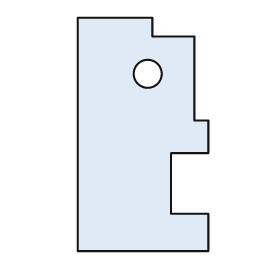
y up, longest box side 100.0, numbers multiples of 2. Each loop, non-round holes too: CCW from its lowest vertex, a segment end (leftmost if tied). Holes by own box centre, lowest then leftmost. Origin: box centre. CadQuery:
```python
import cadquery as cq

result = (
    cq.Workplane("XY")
    .moveTo(-28.0, -50.0)
    .lineTo(28.0, -50.0)
    .lineTo(28.0, -34.0)
    .lineTo(12.0, -34.0)
    .lineTo(12.0, -8.0)
    .lineTo(28.0, -8.0)
    .lineTo(28.0, 6.0)
    .lineTo(22.0, 6.0)
    .lineTo(22.0, 42.0)
    .lineTo(4.0, 42.0)
    .lineTo(4.0, 50.0)
    .lineTo(-28.0, 50.0)
    .close()
    .moveTo(2.0, 26.0)
    .circle(6.0)
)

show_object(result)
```